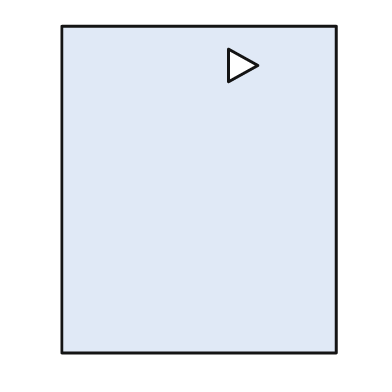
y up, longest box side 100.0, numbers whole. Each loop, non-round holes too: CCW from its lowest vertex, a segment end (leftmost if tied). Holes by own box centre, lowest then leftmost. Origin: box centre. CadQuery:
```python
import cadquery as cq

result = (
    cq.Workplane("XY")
    .moveTo(-42.0, -50.0)
    .lineTo(42.0, -50.0)
    .lineTo(42.0, 50.0)
    .lineTo(-42.0, 50.0)
    .close()
    .moveTo(9.0, 33.0)
    .lineTo(18.0, 38.0)
    .lineTo(9.0, 43.0)
    .close()
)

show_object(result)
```